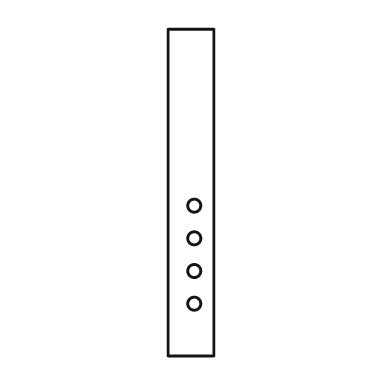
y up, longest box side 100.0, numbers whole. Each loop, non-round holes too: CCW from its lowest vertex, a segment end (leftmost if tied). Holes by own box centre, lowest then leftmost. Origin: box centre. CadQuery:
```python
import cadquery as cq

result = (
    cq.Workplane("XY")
    .moveTo(-7.0, -50.0)
    .lineTo(7.0, -50.0)
    .lineTo(7.0, 50.0)
    .lineTo(-7.0, 50.0)
    .close()
    .moveTo(1.0, -34.0)
    .circle(2.0)
    .moveTo(1.0, -24.0)
    .circle(2.0)
    .moveTo(1.0, -14.0)
    .circle(2.0)
    .moveTo(1.0, -4.0)
    .circle(2.0)
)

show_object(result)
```